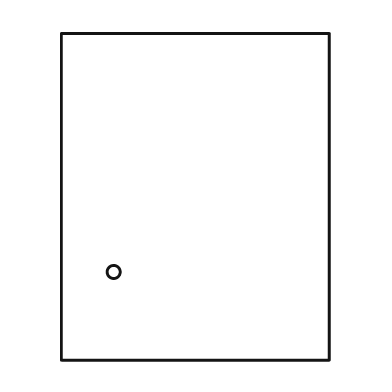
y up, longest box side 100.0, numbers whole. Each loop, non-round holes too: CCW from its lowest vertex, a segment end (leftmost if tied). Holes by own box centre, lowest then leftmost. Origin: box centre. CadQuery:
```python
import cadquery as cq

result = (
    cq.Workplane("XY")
    .moveTo(-41.0, -50.0)
    .lineTo(41.0, -50.0)
    .lineTo(41.0, 50.0)
    .lineTo(-41.0, 50.0)
    .close()
    .moveTo(-25.0, -23.0)
    .circle(2.0)
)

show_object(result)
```